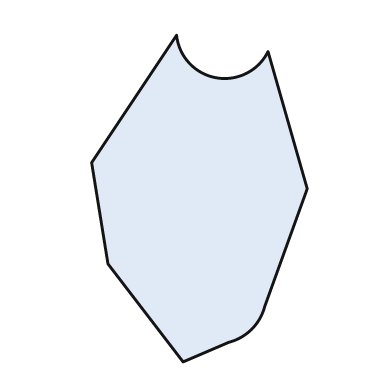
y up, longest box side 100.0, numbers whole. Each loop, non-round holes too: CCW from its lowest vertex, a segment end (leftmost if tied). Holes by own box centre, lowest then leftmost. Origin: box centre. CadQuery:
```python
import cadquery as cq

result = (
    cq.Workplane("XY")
    .moveTo(-5.0, -50.0)
    .lineTo(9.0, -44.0)
    .threePointArc((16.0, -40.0), (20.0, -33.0))
    .lineTo(33.0, 3.0)
    .lineTo(21.0, 45.0)
    .threePointArc((5.0, 37.0), (-7.0, 50.0))
    .lineTo(-33.0, 11.0)
    .lineTo(-28.0, -20.0)
    .close()
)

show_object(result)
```